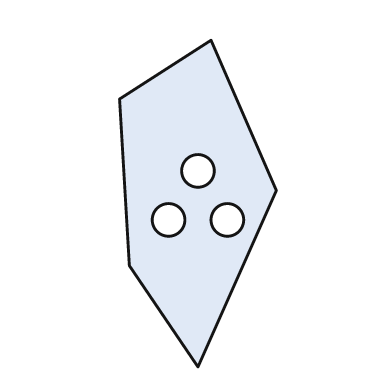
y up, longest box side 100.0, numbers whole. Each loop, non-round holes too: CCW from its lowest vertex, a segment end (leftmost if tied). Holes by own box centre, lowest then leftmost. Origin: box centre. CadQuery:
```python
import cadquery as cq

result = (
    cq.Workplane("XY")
    .moveTo(0.0, -50.0)
    .lineTo(24.0, 4.0)
    .lineTo(4.0, 50.0)
    .lineTo(-24.0, 32.0)
    .lineTo(-21.0, -19.0)
    .close()
    .moveTo(-9.0, -5.0)
    .circle(5.0)
    .moveTo(9.0, -5.0)
    .circle(5.0)
    .moveTo(0.0, 10.0)
    .circle(5.0)
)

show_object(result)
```